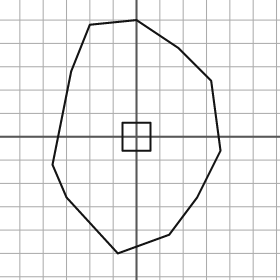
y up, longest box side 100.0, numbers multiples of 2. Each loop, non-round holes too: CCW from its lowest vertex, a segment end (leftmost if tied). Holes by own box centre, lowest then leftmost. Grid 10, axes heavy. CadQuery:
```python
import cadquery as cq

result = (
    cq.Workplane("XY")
    .moveTo(-8.0, -50.0)
    .lineTo(14.0, -42.0)
    .lineTo(26.0, -26.0)
    .lineTo(36.0, -6.0)
    .lineTo(32.0, 24.0)
    .lineTo(18.0, 38.0)
    .lineTo(0.0, 50.0)
    .lineTo(-20.0, 48.0)
    .lineTo(-28.0, 28.0)
    .lineTo(-36.0, -12.0)
    .lineTo(-30.0, -26.0)
    .close()
    .moveTo(-6.0, -6.0)
    .lineTo(6.0, -6.0)
    .lineTo(6.0, 6.0)
    .lineTo(-6.0, 6.0)
    .close()
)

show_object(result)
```